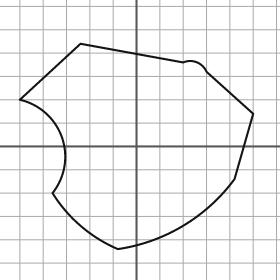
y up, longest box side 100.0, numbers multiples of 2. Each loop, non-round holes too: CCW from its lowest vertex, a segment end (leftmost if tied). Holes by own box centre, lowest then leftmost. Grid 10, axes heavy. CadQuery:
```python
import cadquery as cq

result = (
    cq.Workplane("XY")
    .moveTo(-8.0, -44.0)
    .threePointArc((20.0, -34.0), (42.0, -14.0))
    .lineTo(50.0, 14.0)
    .lineTo(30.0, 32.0)
    .threePointArc((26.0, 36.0), (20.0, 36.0))
    .lineTo(-24.0, 44.0)
    .lineTo(-50.0, 20.0)
    .threePointArc((-32.0, 4.0), (-36.0, -20.0))
    .threePointArc((-24.0, -34.0), (-8.0, -44.0))
    .close()
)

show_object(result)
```